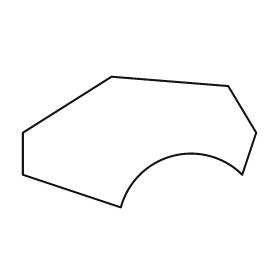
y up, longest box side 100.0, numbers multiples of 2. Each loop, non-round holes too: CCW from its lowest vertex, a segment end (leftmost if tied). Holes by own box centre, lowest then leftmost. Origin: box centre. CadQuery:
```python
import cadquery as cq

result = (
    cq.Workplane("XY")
    .moveTo(-8.0, -28.0)
    .threePointArc((14.0, -6.0), (44.0, -14.0))
    .lineTo(50.0, 4.0)
    .lineTo(38.0, 24.0)
    .lineTo(-12.0, 28.0)
    .lineTo(-50.0, 4.0)
    .lineTo(-50.0, -14.0)
    .close()
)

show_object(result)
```